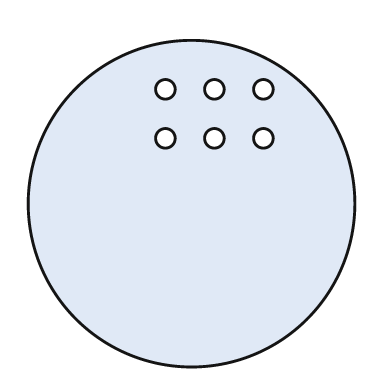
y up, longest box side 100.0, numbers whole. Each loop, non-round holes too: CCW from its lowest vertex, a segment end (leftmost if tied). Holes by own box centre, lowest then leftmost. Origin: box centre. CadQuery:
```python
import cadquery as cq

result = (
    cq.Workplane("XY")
    .moveTo(0.0, 0.0)
    .circle(50.0)
    .moveTo(-8.0, 20.0)
    .circle(3.0)
    .moveTo(7.0, 20.0)
    .circle(3.0)
    .moveTo(22.0, 20.0)
    .circle(3.0)
    .moveTo(-8.0, 35.0)
    .circle(3.0)
    .moveTo(7.0, 35.0)
    .circle(3.0)
    .moveTo(22.0, 35.0)
    .circle(3.0)
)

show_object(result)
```